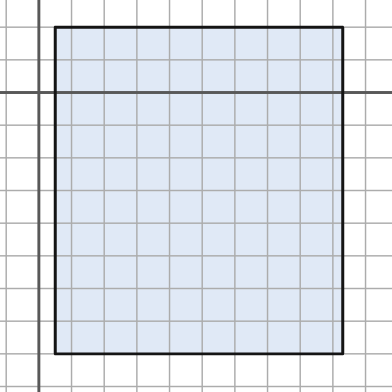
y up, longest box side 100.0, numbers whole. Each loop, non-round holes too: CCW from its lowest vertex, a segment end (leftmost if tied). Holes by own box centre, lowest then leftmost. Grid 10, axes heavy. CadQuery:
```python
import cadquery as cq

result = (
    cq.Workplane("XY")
    .moveTo(5.0, -80.0)
    .lineTo(93.0, -80.0)
    .lineTo(93.0, 20.0)
    .lineTo(5.0, 20.0)
    .close()
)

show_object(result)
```